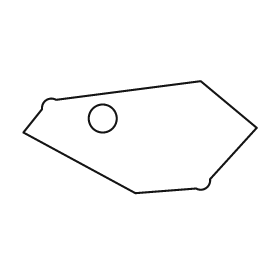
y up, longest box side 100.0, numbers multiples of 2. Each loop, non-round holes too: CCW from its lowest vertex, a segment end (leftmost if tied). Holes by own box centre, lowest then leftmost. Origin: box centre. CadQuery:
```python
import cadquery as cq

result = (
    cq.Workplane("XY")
    .moveTo(-2.0, -24.0)
    .lineTo(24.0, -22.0)
    .threePointArc((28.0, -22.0), (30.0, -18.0))
    .lineTo(50.0, 4.0)
    .lineTo(26.0, 24.0)
    .lineTo(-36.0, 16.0)
    .threePointArc((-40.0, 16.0), (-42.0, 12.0))
    .lineTo(-50.0, 2.0)
    .close()
    .moveTo(-16.0, 8.0)
    .circle(6.0)
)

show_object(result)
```